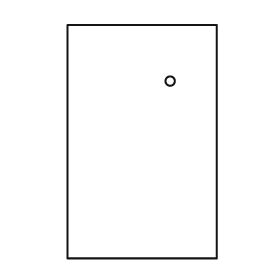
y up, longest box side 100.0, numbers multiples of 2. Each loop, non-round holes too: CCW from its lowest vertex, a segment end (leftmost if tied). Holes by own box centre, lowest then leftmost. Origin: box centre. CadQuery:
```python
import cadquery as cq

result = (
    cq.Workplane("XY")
    .moveTo(-32.0, -50.0)
    .lineTo(32.0, -50.0)
    .lineTo(32.0, 50.0)
    .lineTo(-32.0, 50.0)
    .close()
    .moveTo(12.0, 26.0)
    .circle(2.0)
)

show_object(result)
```